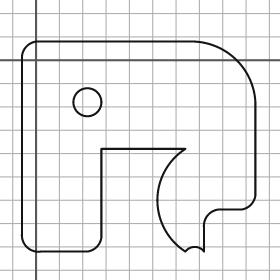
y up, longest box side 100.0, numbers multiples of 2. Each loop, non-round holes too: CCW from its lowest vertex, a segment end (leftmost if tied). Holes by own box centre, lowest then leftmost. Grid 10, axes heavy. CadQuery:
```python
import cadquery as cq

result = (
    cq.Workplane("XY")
    .moveTo(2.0, -82.0)
    .lineTo(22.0, -82.0)
    .threePointArc((26.0, -80.0), (28.0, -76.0))
    .lineTo(28.0, -38.0)
    .lineTo(64.0, -38.0)
    .threePointArc((52.0, -60.0), (64.0, -82.0))
    .threePointArc((68.0, -80.0), (72.0, -82.0))
    .lineTo(72.0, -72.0)
    .threePointArc((74.0, -66.0), (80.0, -64.0))
    .lineTo(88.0, -64.0)
    .threePointArc((92.0, -62.0), (94.0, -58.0))
    .lineTo(94.0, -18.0)
    .threePointArc((86.0, 0.0), (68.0, 8.0))
    .lineTo(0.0, 8.0)
    .threePointArc((-4.0, 6.0), (-6.0, 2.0))
    .lineTo(-6.0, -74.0)
    .threePointArc((-4.0, -80.0), (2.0, -82.0))
    .close()
    .moveTo(22.0, -18.0)
    .circle(6.0)
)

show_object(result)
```